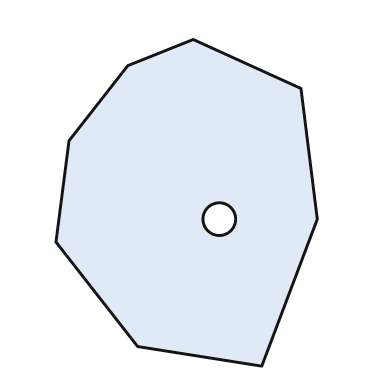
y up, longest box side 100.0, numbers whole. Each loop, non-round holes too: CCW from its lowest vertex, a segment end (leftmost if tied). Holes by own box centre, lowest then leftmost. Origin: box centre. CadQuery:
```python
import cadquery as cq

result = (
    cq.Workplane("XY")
    .moveTo(23.0, -50.0)
    .lineTo(40.0, -5.0)
    .lineTo(35.0, 35.0)
    .lineTo(2.0, 50.0)
    .lineTo(-18.0, 42.0)
    .lineTo(-36.0, 19.0)
    .lineTo(-40.0, -12.0)
    .lineTo(-15.0, -44.0)
    .close()
    .moveTo(10.0, -5.0)
    .circle(5.0)
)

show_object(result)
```